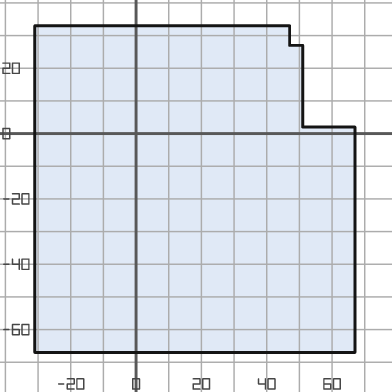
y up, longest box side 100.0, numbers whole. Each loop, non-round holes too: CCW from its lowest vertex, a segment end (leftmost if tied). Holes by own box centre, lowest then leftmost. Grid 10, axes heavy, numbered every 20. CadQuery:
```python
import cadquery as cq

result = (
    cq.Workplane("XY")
    .moveTo(-31.0, -67.0)
    .lineTo(67.0, -67.0)
    .lineTo(67.0, 2.0)
    .lineTo(51.0, 2.0)
    .lineTo(51.0, 27.0)
    .lineTo(47.0, 27.0)
    .lineTo(47.0, 33.0)
    .lineTo(-31.0, 33.0)
    .close()
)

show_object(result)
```